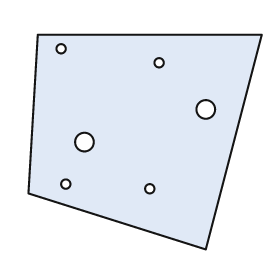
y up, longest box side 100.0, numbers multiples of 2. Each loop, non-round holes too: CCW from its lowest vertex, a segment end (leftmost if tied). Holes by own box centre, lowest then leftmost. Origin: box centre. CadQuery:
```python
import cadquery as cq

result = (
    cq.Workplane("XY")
    .moveTo(26.0, -46.0)
    .lineTo(50.0, 46.0)
    .lineTo(-46.0, 46.0)
    .lineTo(-50.0, -22.0)
    .close()
    .moveTo(2.0, -20.0)
    .circle(2.0)
    .moveTo(-34.0, -18.0)
    .circle(2.0)
    .moveTo(-26.0, 0.0)
    .circle(4.0)
    .moveTo(26.0, 14.0)
    .circle(4.0)
    .moveTo(6.0, 34.0)
    .circle(2.0)
    .moveTo(-36.0, 40.0)
    .circle(2.0)
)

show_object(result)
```